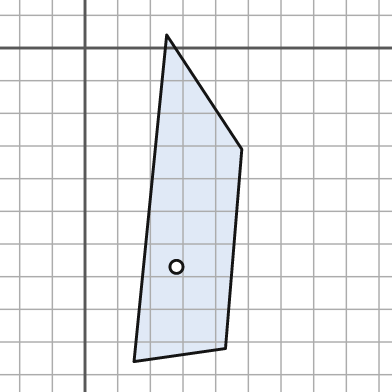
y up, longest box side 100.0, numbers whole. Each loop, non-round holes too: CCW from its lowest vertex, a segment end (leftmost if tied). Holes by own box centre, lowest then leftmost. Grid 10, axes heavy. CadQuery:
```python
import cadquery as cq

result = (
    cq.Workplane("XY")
    .moveTo(15.0, -96.0)
    .lineTo(43.0, -92.0)
    .lineTo(48.0, -31.0)
    .lineTo(25.0, 4.0)
    .close()
    .moveTo(28.0, -67.0)
    .circle(2.0)
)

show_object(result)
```